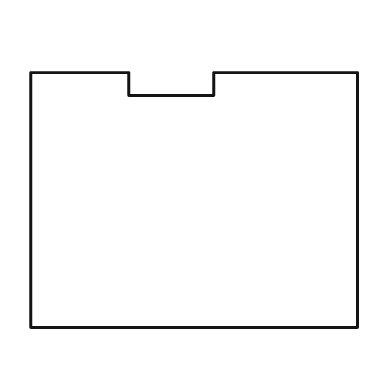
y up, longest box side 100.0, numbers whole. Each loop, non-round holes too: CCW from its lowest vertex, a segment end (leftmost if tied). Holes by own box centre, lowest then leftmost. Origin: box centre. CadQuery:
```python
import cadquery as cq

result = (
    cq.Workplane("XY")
    .moveTo(-50.0, -39.0)
    .lineTo(50.0, -39.0)
    .lineTo(50.0, 39.0)
    .lineTo(6.0, 39.0)
    .lineTo(6.0, 32.0)
    .lineTo(-20.0, 32.0)
    .lineTo(-20.0, 39.0)
    .lineTo(-50.0, 39.0)
    .close()
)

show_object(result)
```